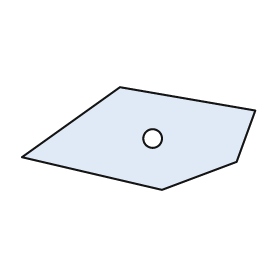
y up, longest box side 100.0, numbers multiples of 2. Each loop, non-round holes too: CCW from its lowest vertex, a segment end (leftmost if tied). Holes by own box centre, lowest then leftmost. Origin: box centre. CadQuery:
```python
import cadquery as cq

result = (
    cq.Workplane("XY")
    .moveTo(10.0, -22.0)
    .lineTo(42.0, -10.0)
    .lineTo(50.0, 12.0)
    .lineTo(-8.0, 22.0)
    .lineTo(-50.0, -8.0)
    .close()
    .moveTo(6.0, 0.0)
    .circle(4.0)
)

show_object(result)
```